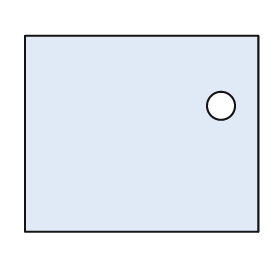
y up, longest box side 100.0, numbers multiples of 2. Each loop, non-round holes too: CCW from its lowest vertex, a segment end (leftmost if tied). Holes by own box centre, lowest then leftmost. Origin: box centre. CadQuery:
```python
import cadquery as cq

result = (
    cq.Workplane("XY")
    .moveTo(-50.0, -42.0)
    .lineTo(50.0, -42.0)
    .lineTo(50.0, 42.0)
    .lineTo(-50.0, 42.0)
    .close()
    .moveTo(34.0, 12.0)
    .circle(6.0)
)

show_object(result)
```